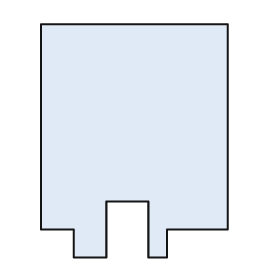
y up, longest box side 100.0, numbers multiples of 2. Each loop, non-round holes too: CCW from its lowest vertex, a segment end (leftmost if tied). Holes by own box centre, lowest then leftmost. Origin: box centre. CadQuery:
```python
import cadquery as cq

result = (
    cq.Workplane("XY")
    .moveTo(-26.0, -50.0)
    .lineTo(-12.0, -50.0)
    .lineTo(-12.0, -26.0)
    .lineTo(6.0, -26.0)
    .lineTo(6.0, -50.0)
    .lineTo(14.0, -50.0)
    .lineTo(14.0, -38.0)
    .lineTo(40.0, -38.0)
    .lineTo(40.0, 50.0)
    .lineTo(-40.0, 50.0)
    .lineTo(-40.0, -38.0)
    .lineTo(-26.0, -38.0)
    .close()
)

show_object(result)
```